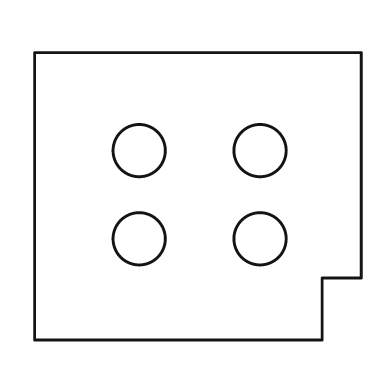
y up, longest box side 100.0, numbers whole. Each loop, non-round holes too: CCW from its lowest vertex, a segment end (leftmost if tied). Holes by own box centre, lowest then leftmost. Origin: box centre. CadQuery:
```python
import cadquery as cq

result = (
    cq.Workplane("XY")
    .moveTo(-50.0, -44.0)
    .lineTo(38.0, -44.0)
    .lineTo(38.0, -25.0)
    .lineTo(50.0, -25.0)
    .lineTo(50.0, 44.0)
    .lineTo(-50.0, 44.0)
    .close()
    .moveTo(-18.0, -13.0)
    .circle(8.0)
    .moveTo(19.0, -13.0)
    .circle(8.0)
    .moveTo(-18.0, 14.0)
    .circle(8.0)
    .moveTo(19.0, 14.0)
    .circle(8.0)
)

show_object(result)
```